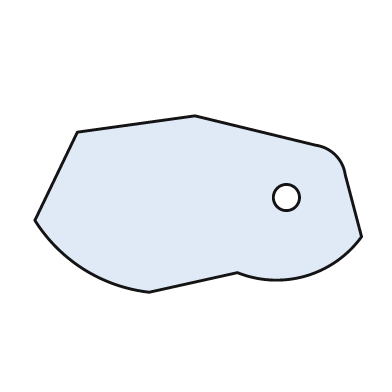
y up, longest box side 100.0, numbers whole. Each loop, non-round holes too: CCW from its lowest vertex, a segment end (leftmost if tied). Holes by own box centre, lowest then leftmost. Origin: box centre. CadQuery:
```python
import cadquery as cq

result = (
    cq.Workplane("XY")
    .moveTo(-15.0, -27.0)
    .lineTo(12.0, -21.0)
    .threePointArc((33.0, -22.0), (50.0, -10.0))
    .lineTo(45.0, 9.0)
    .threePointArc((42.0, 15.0), (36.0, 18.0))
    .lineTo(-1.0, 27.0)
    .lineTo(-37.0, 22.0)
    .lineTo(-50.0, -5.0)
    .threePointArc((-35.0, -20.0), (-15.0, -27.0))
    .close()
    .moveTo(27.0, 2.0)
    .circle(4.0)
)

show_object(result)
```